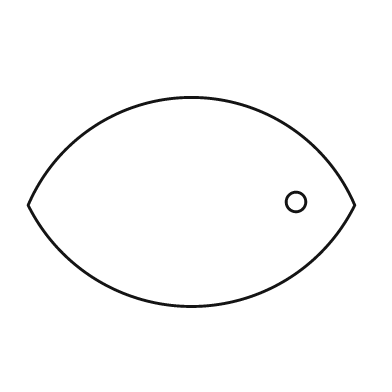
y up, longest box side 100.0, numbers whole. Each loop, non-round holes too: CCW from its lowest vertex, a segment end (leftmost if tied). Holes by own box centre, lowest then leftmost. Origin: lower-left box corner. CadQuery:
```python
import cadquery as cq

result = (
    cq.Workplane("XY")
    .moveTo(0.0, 31.0)
    .threePointArc((50.0, 0.0), (100.0, 31.0))
    .threePointArc((50.0, 64.0), (0.0, 31.0))
    .close()
    .moveTo(82.0, 32.0)
    .circle(3.0)
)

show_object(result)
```